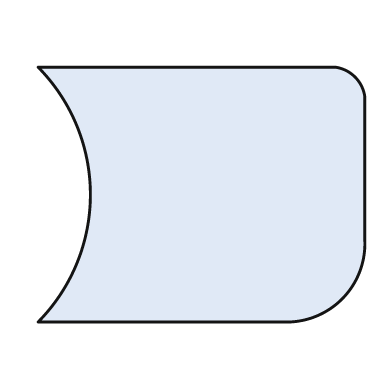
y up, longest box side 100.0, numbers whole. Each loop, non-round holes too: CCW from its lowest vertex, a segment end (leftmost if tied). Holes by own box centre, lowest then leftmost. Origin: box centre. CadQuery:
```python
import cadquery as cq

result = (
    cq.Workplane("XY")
    .moveTo(-50.0, -39.0)
    .lineTo(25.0, -39.0)
    .threePointArc((43.0, -32.0), (50.0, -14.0))
    .lineTo(50.0, 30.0)
    .threePointArc((47.0, 36.0), (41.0, 39.0))
    .lineTo(-50.0, 39.0)
    .threePointArc((-34.0, 0.0), (-50.0, -39.0))
    .close()
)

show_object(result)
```